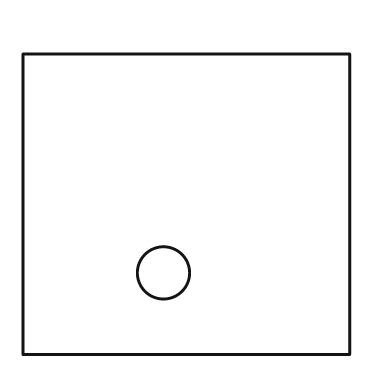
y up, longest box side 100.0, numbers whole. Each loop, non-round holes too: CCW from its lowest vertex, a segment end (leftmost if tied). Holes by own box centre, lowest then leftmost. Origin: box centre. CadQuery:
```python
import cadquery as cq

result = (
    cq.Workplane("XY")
    .moveTo(-50.0, -46.0)
    .lineTo(50.0, -46.0)
    .lineTo(50.0, 46.0)
    .lineTo(-50.0, 46.0)
    .close()
    .moveTo(-7.0, -21.0)
    .circle(8.0)
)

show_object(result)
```